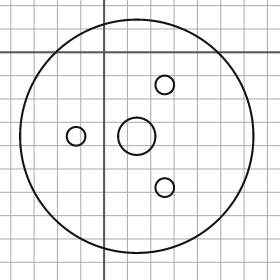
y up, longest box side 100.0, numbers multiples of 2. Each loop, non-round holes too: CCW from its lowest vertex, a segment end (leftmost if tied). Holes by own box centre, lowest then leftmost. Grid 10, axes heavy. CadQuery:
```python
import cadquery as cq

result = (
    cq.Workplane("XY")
    .moveTo(14.0, -36.0)
    .circle(50.0)
    .moveTo(26.0, -58.0)
    .circle(4.0)
    .moveTo(-12.0, -36.0)
    .circle(4.0)
    .moveTo(14.0, -36.0)
    .circle(8.0)
    .moveTo(26.0, -14.0)
    .circle(4.0)
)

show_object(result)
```